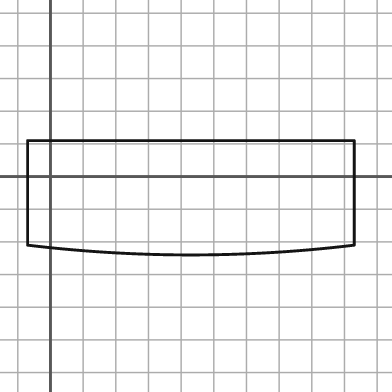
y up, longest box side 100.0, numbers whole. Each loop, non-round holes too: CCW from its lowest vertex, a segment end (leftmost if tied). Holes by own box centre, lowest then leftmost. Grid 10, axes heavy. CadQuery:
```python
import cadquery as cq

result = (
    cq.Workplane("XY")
    .moveTo(-7.0, -21.0)
    .threePointArc((43.0, -24.0), (93.0, -21.0))
    .lineTo(93.0, 11.0)
    .lineTo(-7.0, 11.0)
    .close()
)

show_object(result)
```